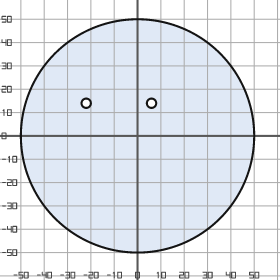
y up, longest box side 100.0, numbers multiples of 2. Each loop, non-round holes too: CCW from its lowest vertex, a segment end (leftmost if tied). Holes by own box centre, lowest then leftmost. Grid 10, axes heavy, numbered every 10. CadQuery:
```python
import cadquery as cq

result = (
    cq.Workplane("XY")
    .moveTo(0.0, 0.0)
    .circle(50.0)
    .moveTo(-22.0, 14.0)
    .circle(2.0)
    .moveTo(6.0, 14.0)
    .circle(2.0)
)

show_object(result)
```